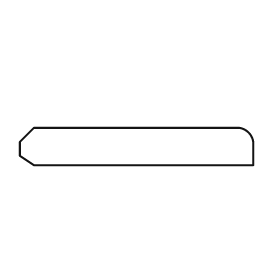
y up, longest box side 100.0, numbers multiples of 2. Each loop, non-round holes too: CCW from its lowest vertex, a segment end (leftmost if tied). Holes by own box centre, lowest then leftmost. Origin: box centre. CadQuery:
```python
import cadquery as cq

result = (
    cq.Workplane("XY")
    .moveTo(-44.0, -8.0)
    .lineTo(50.0, -8.0)
    .lineTo(50.0, 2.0)
    .threePointArc((48.0, 6.0), (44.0, 8.0))
    .lineTo(-44.0, 8.0)
    .lineTo(-50.0, 2.0)
    .lineTo(-50.0, -4.0)
    .close()
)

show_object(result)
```